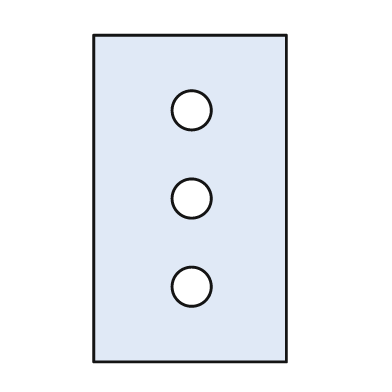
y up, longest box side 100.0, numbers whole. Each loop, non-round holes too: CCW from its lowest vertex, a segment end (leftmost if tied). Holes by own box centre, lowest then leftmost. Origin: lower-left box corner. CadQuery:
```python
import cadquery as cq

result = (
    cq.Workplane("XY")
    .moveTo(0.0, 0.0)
    .lineTo(59.0, 0.0)
    .lineTo(59.0, 100.0)
    .lineTo(0.0, 100.0)
    .close()
    .moveTo(30.0, 23.0)
    .circle(6.0)
    .moveTo(30.0, 50.0)
    .circle(6.0)
    .moveTo(30.0, 77.0)
    .circle(6.0)
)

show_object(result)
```